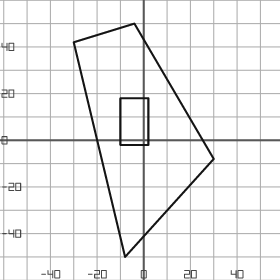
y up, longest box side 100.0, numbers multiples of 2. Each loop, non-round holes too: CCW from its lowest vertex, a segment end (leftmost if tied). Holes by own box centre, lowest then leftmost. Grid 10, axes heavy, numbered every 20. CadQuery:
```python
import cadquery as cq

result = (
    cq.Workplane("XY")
    .moveTo(-8.0, -50.0)
    .lineTo(30.0, -8.0)
    .lineTo(-4.0, 50.0)
    .lineTo(-30.0, 42.0)
    .close()
    .moveTo(-10.0, -2.0)
    .lineTo(2.0, -2.0)
    .lineTo(2.0, 18.0)
    .lineTo(-10.0, 18.0)
    .close()
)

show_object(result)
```